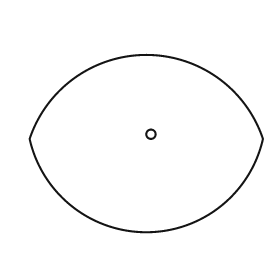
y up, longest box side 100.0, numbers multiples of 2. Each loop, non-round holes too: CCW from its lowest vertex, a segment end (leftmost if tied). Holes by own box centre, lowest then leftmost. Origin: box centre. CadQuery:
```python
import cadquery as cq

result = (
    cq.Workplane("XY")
    .moveTo(-50.0, 2.0)
    .threePointArc((0.0, -38.0), (50.0, 2.0))
    .threePointArc((0.0, 38.0), (-50.0, 2.0))
    .close()
    .moveTo(2.0, 4.0)
    .circle(2.0)
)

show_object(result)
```